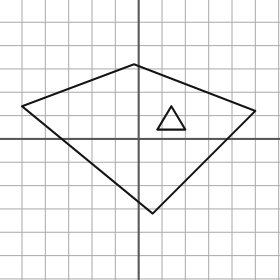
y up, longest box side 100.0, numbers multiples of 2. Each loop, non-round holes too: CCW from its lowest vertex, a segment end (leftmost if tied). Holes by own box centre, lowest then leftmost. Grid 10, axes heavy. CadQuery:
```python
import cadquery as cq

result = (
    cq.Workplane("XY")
    .moveTo(6.0, -32.0)
    .lineTo(50.0, 12.0)
    .lineTo(-2.0, 32.0)
    .lineTo(-50.0, 14.0)
    .close()
    .moveTo(8.0, 4.0)
    .lineTo(20.0, 4.0)
    .lineTo(14.0, 14.0)
    .close()
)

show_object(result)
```